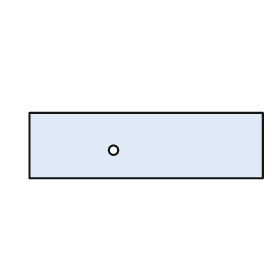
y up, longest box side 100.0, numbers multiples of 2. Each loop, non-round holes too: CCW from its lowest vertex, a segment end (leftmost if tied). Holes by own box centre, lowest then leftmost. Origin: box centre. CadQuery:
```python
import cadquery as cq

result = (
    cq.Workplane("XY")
    .moveTo(-50.0, -14.0)
    .lineTo(50.0, -14.0)
    .lineTo(50.0, 14.0)
    .lineTo(-50.0, 14.0)
    .close()
    .moveTo(-14.0, -2.0)
    .circle(2.0)
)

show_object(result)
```